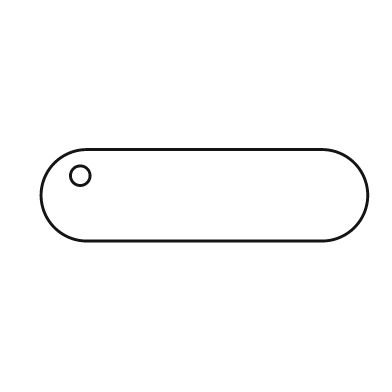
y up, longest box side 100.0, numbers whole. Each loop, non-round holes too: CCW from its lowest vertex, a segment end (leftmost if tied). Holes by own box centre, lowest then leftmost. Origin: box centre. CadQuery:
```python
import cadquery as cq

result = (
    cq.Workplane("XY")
    .moveTo(-36.0, -14.0)
    .lineTo(36.0, -14.0)
    .threePointArc((50.0, 0.0), (36.0, 14.0))
    .lineTo(-36.0, 14.0)
    .threePointArc((-50.0, 0.0), (-36.0, -14.0))
    .close()
    .moveTo(-38.0, 6.0)
    .circle(3.0)
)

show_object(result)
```